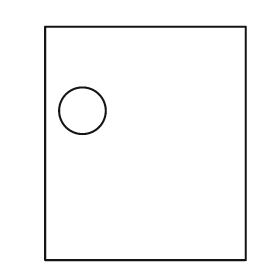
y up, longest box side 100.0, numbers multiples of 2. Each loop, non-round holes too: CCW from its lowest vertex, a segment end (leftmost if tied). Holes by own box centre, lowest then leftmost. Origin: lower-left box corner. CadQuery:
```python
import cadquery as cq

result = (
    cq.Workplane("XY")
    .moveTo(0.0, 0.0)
    .lineTo(86.0, 0.0)
    .lineTo(86.0, 100.0)
    .lineTo(0.0, 100.0)
    .close()
    .moveTo(16.0, 64.0)
    .circle(10.0)
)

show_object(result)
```